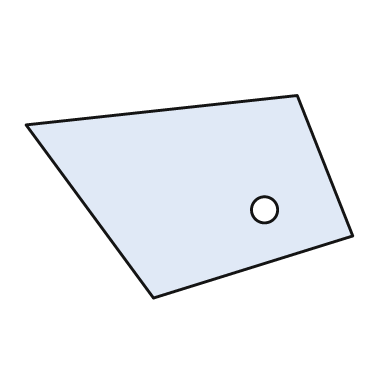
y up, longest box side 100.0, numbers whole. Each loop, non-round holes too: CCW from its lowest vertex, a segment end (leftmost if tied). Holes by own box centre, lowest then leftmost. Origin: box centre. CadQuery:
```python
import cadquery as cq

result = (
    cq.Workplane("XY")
    .moveTo(-11.0, -31.0)
    .lineTo(50.0, -12.0)
    .lineTo(33.0, 31.0)
    .lineTo(-50.0, 22.0)
    .close()
    .moveTo(23.0, -4.0)
    .circle(4.0)
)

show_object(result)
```